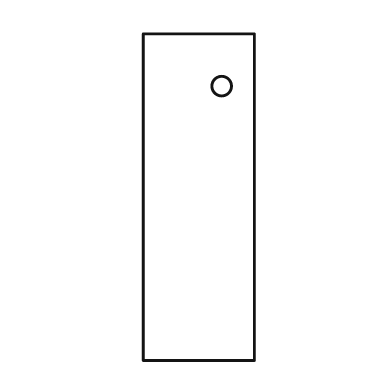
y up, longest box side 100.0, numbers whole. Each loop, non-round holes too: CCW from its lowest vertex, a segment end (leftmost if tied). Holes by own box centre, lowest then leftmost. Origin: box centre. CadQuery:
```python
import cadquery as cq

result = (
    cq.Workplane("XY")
    .moveTo(-17.0, -50.0)
    .lineTo(17.0, -50.0)
    .lineTo(17.0, 50.0)
    .lineTo(-17.0, 50.0)
    .close()
    .moveTo(7.0, 34.0)
    .circle(3.0)
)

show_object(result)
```